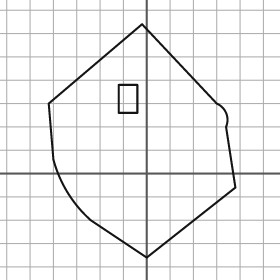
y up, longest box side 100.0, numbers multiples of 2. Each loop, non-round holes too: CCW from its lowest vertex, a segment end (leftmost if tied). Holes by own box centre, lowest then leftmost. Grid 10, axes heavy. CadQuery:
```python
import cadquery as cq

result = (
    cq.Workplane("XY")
    .moveTo(0.0, -36.0)
    .lineTo(38.0, -6.0)
    .lineTo(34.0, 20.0)
    .threePointArc((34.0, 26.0), (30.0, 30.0))
    .lineTo(-2.0, 64.0)
    .lineTo(-42.0, 30.0)
    .lineTo(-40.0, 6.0)
    .threePointArc((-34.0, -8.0), (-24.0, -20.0))
    .close()
    .moveTo(-12.0, 26.0)
    .lineTo(-4.0, 26.0)
    .lineTo(-4.0, 38.0)
    .lineTo(-12.0, 38.0)
    .close()
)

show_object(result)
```